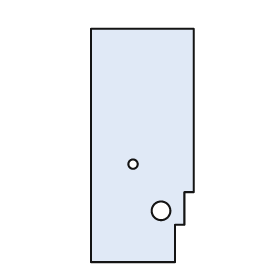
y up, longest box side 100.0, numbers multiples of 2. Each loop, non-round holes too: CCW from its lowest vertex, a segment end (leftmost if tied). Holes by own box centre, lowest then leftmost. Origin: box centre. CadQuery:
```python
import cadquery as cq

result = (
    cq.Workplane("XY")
    .moveTo(-22.0, -50.0)
    .lineTo(14.0, -50.0)
    .lineTo(14.0, -34.0)
    .lineTo(18.0, -34.0)
    .lineTo(18.0, -20.0)
    .lineTo(22.0, -20.0)
    .lineTo(22.0, 50.0)
    .lineTo(-22.0, 50.0)
    .close()
    .moveTo(8.0, -28.0)
    .circle(4.0)
    .moveTo(-4.0, -8.0)
    .circle(2.0)
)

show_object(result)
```